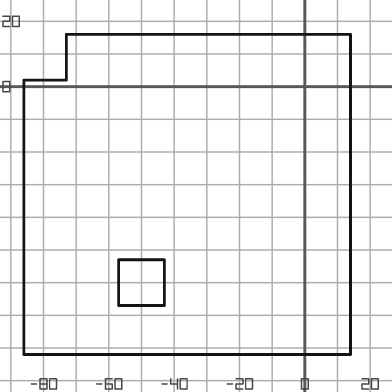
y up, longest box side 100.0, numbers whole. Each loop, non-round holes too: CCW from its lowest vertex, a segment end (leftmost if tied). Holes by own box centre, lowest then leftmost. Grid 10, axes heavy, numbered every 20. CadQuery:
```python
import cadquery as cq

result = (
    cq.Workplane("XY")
    .moveTo(-86.0, -82.0)
    .lineTo(14.0, -82.0)
    .lineTo(14.0, 16.0)
    .lineTo(-73.0, 16.0)
    .lineTo(-73.0, 2.0)
    .lineTo(-86.0, 2.0)
    .close()
    .moveTo(-57.0, -67.0)
    .lineTo(-43.0, -67.0)
    .lineTo(-43.0, -53.0)
    .lineTo(-57.0, -53.0)
    .close()
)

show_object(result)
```